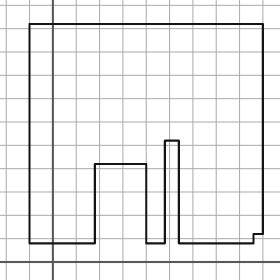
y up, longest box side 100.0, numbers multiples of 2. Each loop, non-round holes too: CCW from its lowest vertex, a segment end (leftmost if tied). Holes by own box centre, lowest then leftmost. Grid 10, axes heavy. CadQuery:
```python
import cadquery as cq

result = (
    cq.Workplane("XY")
    .moveTo(-10.0, 8.0)
    .lineTo(18.0, 8.0)
    .lineTo(18.0, 42.0)
    .lineTo(40.0, 42.0)
    .lineTo(40.0, 8.0)
    .lineTo(48.0, 8.0)
    .lineTo(48.0, 52.0)
    .lineTo(54.0, 52.0)
    .lineTo(54.0, 8.0)
    .lineTo(86.0, 8.0)
    .lineTo(86.0, 12.0)
    .lineTo(90.0, 12.0)
    .lineTo(90.0, 102.0)
    .lineTo(-10.0, 102.0)
    .close()
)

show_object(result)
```